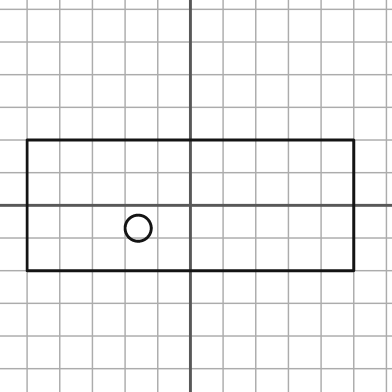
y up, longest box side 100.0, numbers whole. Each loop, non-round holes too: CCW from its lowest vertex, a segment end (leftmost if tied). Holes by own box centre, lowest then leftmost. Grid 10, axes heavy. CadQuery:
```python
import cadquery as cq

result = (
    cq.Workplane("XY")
    .moveTo(-50.0, -20.0)
    .lineTo(50.0, -20.0)
    .lineTo(50.0, 20.0)
    .lineTo(-50.0, 20.0)
    .close()
    .moveTo(-16.0, -7.0)
    .circle(4.0)
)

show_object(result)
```